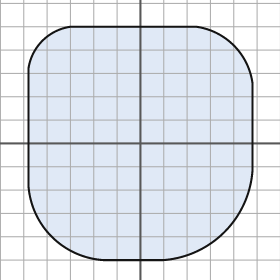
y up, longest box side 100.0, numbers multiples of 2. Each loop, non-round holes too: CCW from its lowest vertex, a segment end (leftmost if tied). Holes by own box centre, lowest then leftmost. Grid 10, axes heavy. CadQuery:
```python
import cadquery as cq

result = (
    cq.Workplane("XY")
    .moveTo(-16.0, -50.0)
    .lineTo(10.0, -50.0)
    .threePointArc((36.0, -38.0), (48.0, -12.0))
    .lineTo(48.0, 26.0)
    .threePointArc((40.0, 42.0), (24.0, 50.0))
    .lineTo(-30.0, 50.0)
    .threePointArc((-42.0, 44.0), (-48.0, 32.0))
    .lineTo(-48.0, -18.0)
    .threePointArc((-38.0, -40.0), (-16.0, -50.0))
    .close()
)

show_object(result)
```